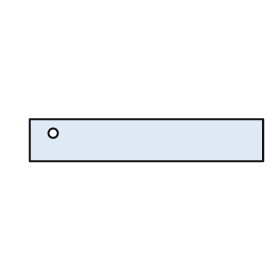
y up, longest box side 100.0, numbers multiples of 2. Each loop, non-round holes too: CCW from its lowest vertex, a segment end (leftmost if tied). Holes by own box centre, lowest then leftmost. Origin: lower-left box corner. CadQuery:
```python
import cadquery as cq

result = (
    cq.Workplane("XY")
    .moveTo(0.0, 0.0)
    .lineTo(100.0, 0.0)
    .lineTo(100.0, 18.0)
    .lineTo(0.0, 18.0)
    .close()
    .moveTo(10.0, 12.0)
    .circle(2.0)
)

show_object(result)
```